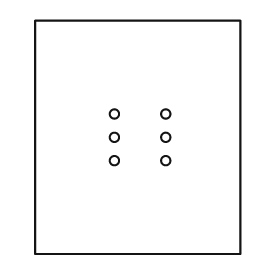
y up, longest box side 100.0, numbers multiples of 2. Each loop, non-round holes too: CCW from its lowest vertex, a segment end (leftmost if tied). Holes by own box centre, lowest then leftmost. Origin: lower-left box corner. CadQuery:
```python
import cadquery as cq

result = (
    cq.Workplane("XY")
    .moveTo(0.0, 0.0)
    .lineTo(88.0, 0.0)
    .lineTo(88.0, 100.0)
    .lineTo(0.0, 100.0)
    .close()
    .moveTo(34.0, 40.0)
    .circle(2.0)
    .moveTo(56.0, 40.0)
    .circle(2.0)
    .moveTo(34.0, 50.0)
    .circle(2.0)
    .moveTo(56.0, 50.0)
    .circle(2.0)
    .moveTo(34.0, 60.0)
    .circle(2.0)
    .moveTo(56.0, 60.0)
    .circle(2.0)
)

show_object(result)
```